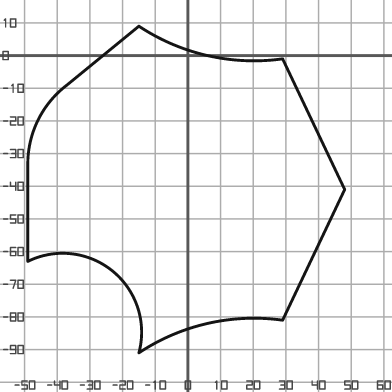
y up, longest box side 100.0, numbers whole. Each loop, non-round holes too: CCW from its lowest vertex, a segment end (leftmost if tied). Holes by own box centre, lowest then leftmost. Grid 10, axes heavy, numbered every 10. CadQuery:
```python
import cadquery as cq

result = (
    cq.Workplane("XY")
    .moveTo(-15.0, -91.0)
    .threePointArc((6.0, -82.0), (29.0, -81.0))
    .lineTo(48.0, -41.0)
    .lineTo(29.0, -1.0)
    .threePointArc((6.0, 0.0), (-15.0, 9.0))
    .lineTo(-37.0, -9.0)
    .threePointArc((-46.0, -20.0), (-49.0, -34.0))
    .lineTo(-49.0, -63.0)
    .threePointArc((-23.0, -66.0), (-15.0, -91.0))
    .close()
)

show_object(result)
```